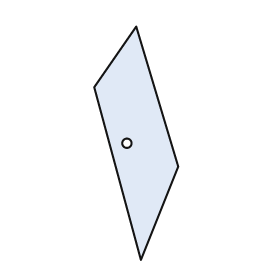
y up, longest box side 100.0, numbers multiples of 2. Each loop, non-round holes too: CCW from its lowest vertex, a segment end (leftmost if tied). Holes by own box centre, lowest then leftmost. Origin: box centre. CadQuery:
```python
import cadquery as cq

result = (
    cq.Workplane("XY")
    .moveTo(2.0, -50.0)
    .lineTo(18.0, -10.0)
    .lineTo(0.0, 50.0)
    .lineTo(-18.0, 24.0)
    .close()
    .moveTo(-4.0, 0.0)
    .circle(2.0)
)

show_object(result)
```